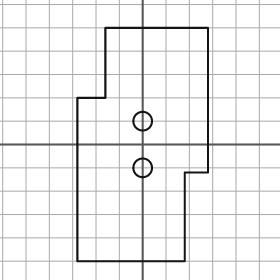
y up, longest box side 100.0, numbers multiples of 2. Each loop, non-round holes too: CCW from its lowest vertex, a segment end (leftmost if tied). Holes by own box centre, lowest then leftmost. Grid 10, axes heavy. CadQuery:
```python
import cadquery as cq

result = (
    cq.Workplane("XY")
    .moveTo(-28.0, -50.0)
    .lineTo(18.0, -50.0)
    .lineTo(18.0, -12.0)
    .lineTo(28.0, -12.0)
    .lineTo(28.0, 50.0)
    .lineTo(-16.0, 50.0)
    .lineTo(-16.0, 20.0)
    .lineTo(-28.0, 20.0)
    .close()
    .moveTo(0.0, -10.0)
    .circle(4.0)
    .moveTo(0.0, 10.0)
    .circle(4.0)
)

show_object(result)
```